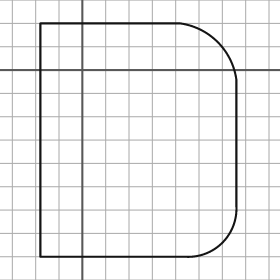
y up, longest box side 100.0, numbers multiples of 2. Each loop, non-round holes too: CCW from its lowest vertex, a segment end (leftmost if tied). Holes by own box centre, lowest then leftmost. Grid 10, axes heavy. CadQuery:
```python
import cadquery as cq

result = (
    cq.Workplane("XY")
    .moveTo(-18.0, -80.0)
    .lineTo(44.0, -80.0)
    .threePointArc((60.0, -74.0), (66.0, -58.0))
    .lineTo(66.0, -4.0)
    .threePointArc((58.0, 12.0), (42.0, 20.0))
    .lineTo(-18.0, 20.0)
    .close()
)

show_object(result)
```